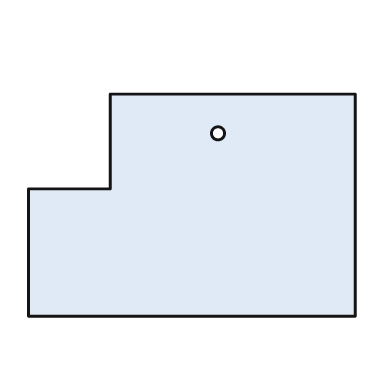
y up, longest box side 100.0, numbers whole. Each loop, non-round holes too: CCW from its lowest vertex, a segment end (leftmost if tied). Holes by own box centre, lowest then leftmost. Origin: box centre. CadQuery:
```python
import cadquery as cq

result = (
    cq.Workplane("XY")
    .moveTo(-50.0, -34.0)
    .lineTo(50.0, -34.0)
    .lineTo(50.0, 34.0)
    .lineTo(-25.0, 34.0)
    .lineTo(-25.0, 5.0)
    .lineTo(-50.0, 5.0)
    .close()
    .moveTo(8.0, 22.0)
    .circle(2.0)
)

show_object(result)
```